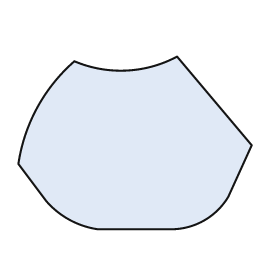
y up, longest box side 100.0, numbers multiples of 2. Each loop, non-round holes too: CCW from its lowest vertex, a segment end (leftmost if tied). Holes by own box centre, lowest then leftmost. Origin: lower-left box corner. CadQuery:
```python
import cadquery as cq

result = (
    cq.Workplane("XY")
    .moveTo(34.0, 0.0)
    .lineTo(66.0, 0.0)
    .threePointArc((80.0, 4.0), (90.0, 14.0))
    .lineTo(100.0, 36.0)
    .lineTo(68.0, 74.0)
    .threePointArc((46.0, 68.0), (24.0, 72.0))
    .threePointArc((8.0, 52.0), (0.0, 28.0))
    .lineTo(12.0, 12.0)
    .threePointArc((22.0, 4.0), (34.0, 0.0))
    .close()
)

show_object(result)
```